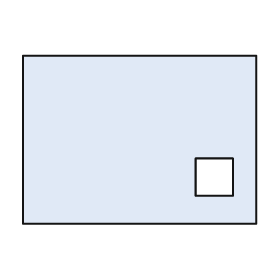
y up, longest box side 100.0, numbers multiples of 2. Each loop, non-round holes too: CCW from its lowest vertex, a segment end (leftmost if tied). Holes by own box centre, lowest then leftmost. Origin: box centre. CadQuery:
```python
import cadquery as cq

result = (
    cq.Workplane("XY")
    .moveTo(-50.0, -36.0)
    .lineTo(50.0, -36.0)
    .lineTo(50.0, 36.0)
    .lineTo(-50.0, 36.0)
    .close()
    .moveTo(24.0, -24.0)
    .lineTo(40.0, -24.0)
    .lineTo(40.0, -8.0)
    .lineTo(24.0, -8.0)
    .close()
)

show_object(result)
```